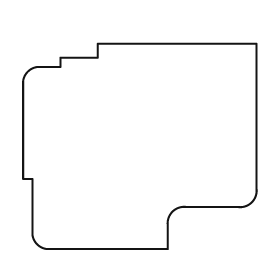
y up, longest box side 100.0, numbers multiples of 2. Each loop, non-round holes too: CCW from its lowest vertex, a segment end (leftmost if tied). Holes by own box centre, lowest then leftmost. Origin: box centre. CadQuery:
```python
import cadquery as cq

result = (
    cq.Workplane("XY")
    .moveTo(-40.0, -44.0)
    .lineTo(12.0, -44.0)
    .lineTo(12.0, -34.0)
    .threePointArc((14.0, -28.0), (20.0, -26.0))
    .lineTo(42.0, -26.0)
    .threePointArc((48.0, -24.0), (50.0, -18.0))
    .lineTo(50.0, 44.0)
    .lineTo(-18.0, 44.0)
    .lineTo(-18.0, 38.0)
    .lineTo(-34.0, 38.0)
    .lineTo(-34.0, 34.0)
    .lineTo(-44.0, 34.0)
    .threePointArc((-48.0, 32.0), (-50.0, 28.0))
    .lineTo(-50.0, -14.0)
    .lineTo(-46.0, -14.0)
    .lineTo(-46.0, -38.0)
    .threePointArc((-44.0, -42.0), (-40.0, -44.0))
    .close()
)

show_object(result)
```